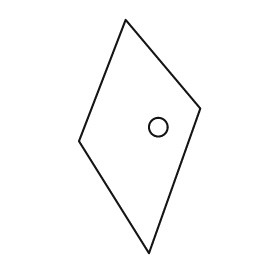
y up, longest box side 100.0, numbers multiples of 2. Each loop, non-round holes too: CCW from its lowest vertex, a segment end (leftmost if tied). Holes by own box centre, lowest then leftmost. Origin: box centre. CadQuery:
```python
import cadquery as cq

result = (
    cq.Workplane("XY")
    .moveTo(4.0, -50.0)
    .lineTo(26.0, 12.0)
    .lineTo(-6.0, 50.0)
    .lineTo(-26.0, -2.0)
    .close()
    .moveTo(8.0, 4.0)
    .circle(4.0)
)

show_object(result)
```